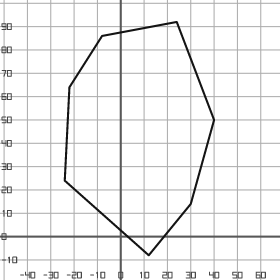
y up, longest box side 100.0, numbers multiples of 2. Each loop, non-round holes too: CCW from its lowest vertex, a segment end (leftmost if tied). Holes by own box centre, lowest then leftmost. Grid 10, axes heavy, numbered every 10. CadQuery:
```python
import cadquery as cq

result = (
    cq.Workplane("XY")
    .moveTo(12.0, -8.0)
    .lineTo(30.0, 14.0)
    .lineTo(40.0, 50.0)
    .lineTo(24.0, 92.0)
    .lineTo(-8.0, 86.0)
    .lineTo(-22.0, 64.0)
    .lineTo(-24.0, 24.0)
    .close()
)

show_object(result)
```